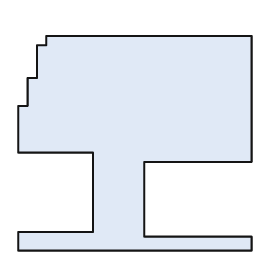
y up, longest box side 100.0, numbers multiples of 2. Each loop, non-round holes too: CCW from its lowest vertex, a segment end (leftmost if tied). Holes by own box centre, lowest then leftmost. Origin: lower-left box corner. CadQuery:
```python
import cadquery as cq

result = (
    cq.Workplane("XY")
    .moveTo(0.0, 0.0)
    .lineTo(100.0, 0.0)
    .lineTo(100.0, 6.0)
    .lineTo(54.0, 6.0)
    .lineTo(54.0, 38.0)
    .lineTo(100.0, 38.0)
    .lineTo(100.0, 92.0)
    .lineTo(12.0, 92.0)
    .lineTo(12.0, 88.0)
    .lineTo(8.0, 88.0)
    .lineTo(8.0, 74.0)
    .lineTo(4.0, 74.0)
    .lineTo(4.0, 62.0)
    .lineTo(0.0, 62.0)
    .lineTo(0.0, 42.0)
    .lineTo(32.0, 42.0)
    .lineTo(32.0, 8.0)
    .lineTo(0.0, 8.0)
    .close()
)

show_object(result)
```